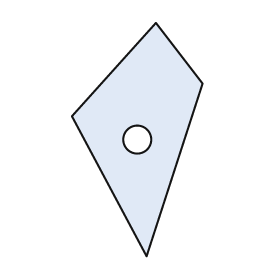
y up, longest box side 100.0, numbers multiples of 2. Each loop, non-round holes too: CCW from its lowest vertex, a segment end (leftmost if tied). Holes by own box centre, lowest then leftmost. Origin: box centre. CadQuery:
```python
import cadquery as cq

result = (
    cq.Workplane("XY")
    .moveTo(4.0, -50.0)
    .lineTo(28.0, 24.0)
    .lineTo(8.0, 50.0)
    .lineTo(-28.0, 10.0)
    .close()
    .moveTo(0.0, 0.0)
    .circle(6.0)
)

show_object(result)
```